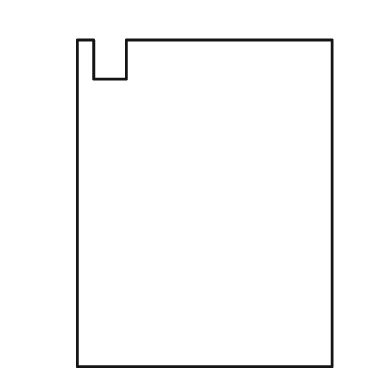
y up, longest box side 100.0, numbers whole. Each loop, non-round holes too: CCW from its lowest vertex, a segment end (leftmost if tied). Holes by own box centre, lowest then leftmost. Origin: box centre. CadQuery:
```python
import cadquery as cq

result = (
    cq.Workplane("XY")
    .moveTo(-39.0, -50.0)
    .lineTo(39.0, -50.0)
    .lineTo(39.0, 50.0)
    .lineTo(-24.0, 50.0)
    .lineTo(-24.0, 38.0)
    .lineTo(-34.0, 38.0)
    .lineTo(-34.0, 50.0)
    .lineTo(-39.0, 50.0)
    .close()
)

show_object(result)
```